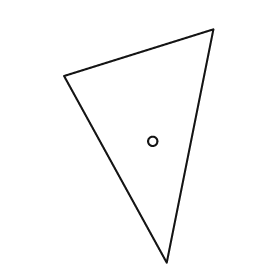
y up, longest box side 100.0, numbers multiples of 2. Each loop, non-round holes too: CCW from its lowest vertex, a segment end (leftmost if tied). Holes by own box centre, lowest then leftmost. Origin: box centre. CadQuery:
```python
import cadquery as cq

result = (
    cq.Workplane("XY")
    .moveTo(12.0, -50.0)
    .lineTo(32.0, 50.0)
    .lineTo(-32.0, 30.0)
    .close()
    .moveTo(6.0, 2.0)
    .circle(2.0)
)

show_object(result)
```